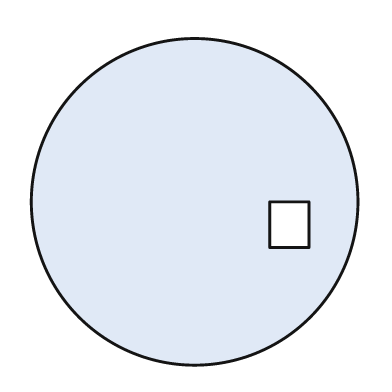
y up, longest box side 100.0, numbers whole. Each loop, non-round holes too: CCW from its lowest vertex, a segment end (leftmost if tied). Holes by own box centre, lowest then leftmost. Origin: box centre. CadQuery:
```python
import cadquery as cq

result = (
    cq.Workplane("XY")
    .moveTo(0.0, 0.0)
    .circle(50.0)
    .moveTo(23.0, -14.0)
    .lineTo(35.0, -14.0)
    .lineTo(35.0, 0.0)
    .lineTo(23.0, 0.0)
    .close()
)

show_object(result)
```